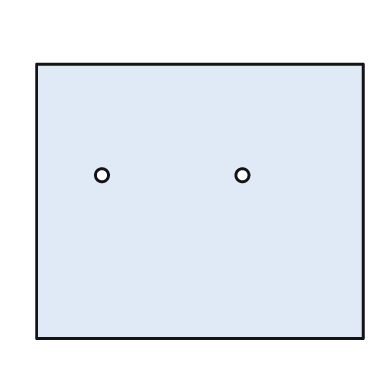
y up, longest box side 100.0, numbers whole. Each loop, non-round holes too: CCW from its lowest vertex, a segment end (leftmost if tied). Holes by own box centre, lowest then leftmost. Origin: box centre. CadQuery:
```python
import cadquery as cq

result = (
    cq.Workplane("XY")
    .moveTo(-50.0, -42.0)
    .lineTo(50.0, -42.0)
    .lineTo(50.0, 42.0)
    .lineTo(-50.0, 42.0)
    .close()
    .moveTo(-30.0, 8.0)
    .circle(2.0)
    .moveTo(13.0, 8.0)
    .circle(2.0)
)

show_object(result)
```